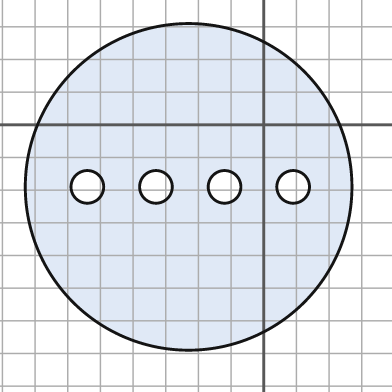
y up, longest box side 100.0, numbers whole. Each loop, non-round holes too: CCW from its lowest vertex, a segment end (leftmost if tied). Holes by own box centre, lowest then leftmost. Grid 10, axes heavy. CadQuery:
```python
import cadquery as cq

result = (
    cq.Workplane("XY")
    .moveTo(-23.0, -19.0)
    .circle(50.0)
    .moveTo(-54.0, -19.0)
    .circle(5.0)
    .moveTo(-33.0, -19.0)
    .circle(5.0)
    .moveTo(-12.0, -19.0)
    .circle(5.0)
    .moveTo(9.0, -19.0)
    .circle(5.0)
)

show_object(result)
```